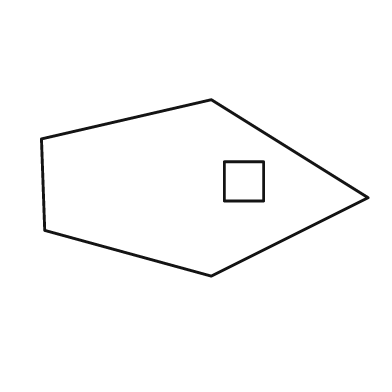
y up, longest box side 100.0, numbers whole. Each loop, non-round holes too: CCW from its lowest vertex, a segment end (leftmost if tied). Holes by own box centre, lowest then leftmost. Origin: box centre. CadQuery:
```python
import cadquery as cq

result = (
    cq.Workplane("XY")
    .moveTo(2.0, -27.0)
    .lineTo(50.0, -3.0)
    .lineTo(2.0, 27.0)
    .lineTo(-50.0, 15.0)
    .lineTo(-49.0, -13.0)
    .close()
    .moveTo(6.0, -4.0)
    .lineTo(18.0, -4.0)
    .lineTo(18.0, 8.0)
    .lineTo(6.0, 8.0)
    .close()
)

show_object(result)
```